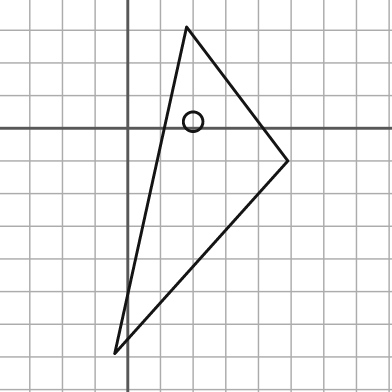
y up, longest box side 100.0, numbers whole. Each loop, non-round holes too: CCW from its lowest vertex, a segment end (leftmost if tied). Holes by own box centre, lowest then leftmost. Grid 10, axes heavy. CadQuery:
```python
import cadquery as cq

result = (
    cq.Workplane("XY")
    .moveTo(-4.0, -69.0)
    .lineTo(49.0, -10.0)
    .lineTo(18.0, 31.0)
    .close()
    .moveTo(20.0, 2.0)
    .circle(3.0)
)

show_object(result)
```